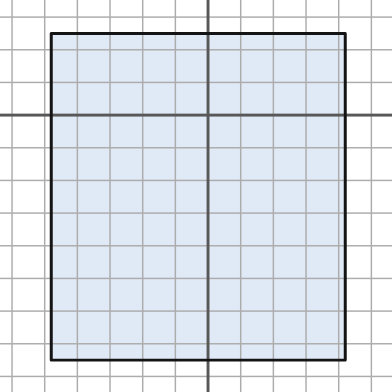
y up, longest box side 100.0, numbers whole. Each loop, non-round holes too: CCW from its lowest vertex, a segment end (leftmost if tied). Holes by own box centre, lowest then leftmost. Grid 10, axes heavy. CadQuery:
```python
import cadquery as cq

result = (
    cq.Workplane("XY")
    .moveTo(-48.0, -75.0)
    .lineTo(42.0, -75.0)
    .lineTo(42.0, 25.0)
    .lineTo(-48.0, 25.0)
    .close()
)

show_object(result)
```